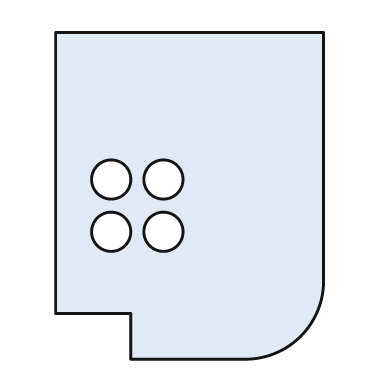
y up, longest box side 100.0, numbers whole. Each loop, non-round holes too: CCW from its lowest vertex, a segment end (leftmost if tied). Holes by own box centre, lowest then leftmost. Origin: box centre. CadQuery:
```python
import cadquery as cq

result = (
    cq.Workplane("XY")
    .moveTo(-18.0, -50.0)
    .lineTo(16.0, -50.0)
    .threePointArc((34.0, -43.0), (41.0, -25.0))
    .lineTo(41.0, 50.0)
    .lineTo(-41.0, 50.0)
    .lineTo(-41.0, -36.0)
    .lineTo(-18.0, -36.0)
    .close()
    .moveTo(-24.0, -11.0)
    .circle(6.0)
    .moveTo(-8.0, -11.0)
    .circle(6.0)
    .moveTo(-24.0, 5.0)
    .circle(6.0)
    .moveTo(-8.0, 5.0)
    .circle(6.0)
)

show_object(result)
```